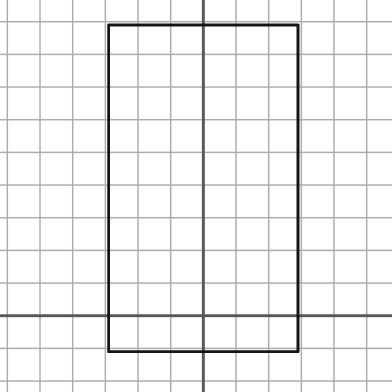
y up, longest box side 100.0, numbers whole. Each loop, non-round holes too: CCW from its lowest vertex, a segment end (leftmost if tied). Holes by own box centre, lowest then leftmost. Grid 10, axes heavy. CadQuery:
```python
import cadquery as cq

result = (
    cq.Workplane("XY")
    .moveTo(-29.0, -11.0)
    .lineTo(29.0, -11.0)
    .lineTo(29.0, 89.0)
    .lineTo(-29.0, 89.0)
    .close()
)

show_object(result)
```